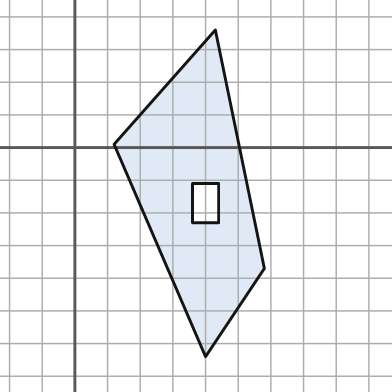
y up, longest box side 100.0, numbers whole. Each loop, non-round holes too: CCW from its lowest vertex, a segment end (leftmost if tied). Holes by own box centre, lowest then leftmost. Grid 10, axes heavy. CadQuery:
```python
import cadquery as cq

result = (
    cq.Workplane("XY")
    .moveTo(40.0, -64.0)
    .lineTo(58.0, -37.0)
    .lineTo(43.0, 36.0)
    .lineTo(12.0, 1.0)
    .close()
    .moveTo(36.0, -23.0)
    .lineTo(44.0, -23.0)
    .lineTo(44.0, -11.0)
    .lineTo(36.0, -11.0)
    .close()
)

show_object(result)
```